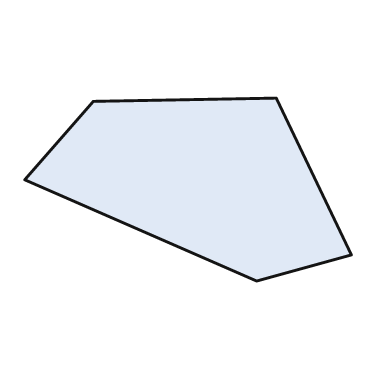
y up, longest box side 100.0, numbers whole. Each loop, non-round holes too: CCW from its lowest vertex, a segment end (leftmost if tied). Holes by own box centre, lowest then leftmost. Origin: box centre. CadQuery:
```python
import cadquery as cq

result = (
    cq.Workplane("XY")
    .moveTo(21.0, -28.0)
    .lineTo(50.0, -20.0)
    .lineTo(27.0, 28.0)
    .lineTo(-29.0, 27.0)
    .lineTo(-50.0, 3.0)
    .close()
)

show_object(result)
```